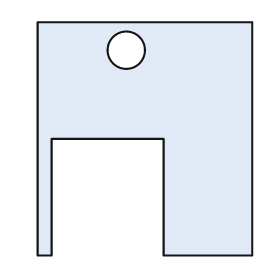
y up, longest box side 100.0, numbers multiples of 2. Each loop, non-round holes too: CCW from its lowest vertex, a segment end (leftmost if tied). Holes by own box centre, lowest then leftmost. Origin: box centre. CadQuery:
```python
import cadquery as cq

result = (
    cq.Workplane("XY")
    .moveTo(-46.0, -50.0)
    .lineTo(-40.0, -50.0)
    .lineTo(-40.0, 0.0)
    .lineTo(8.0, 0.0)
    .lineTo(8.0, -50.0)
    .lineTo(46.0, -50.0)
    .lineTo(46.0, 50.0)
    .lineTo(-46.0, 50.0)
    .close()
    .moveTo(-8.0, 38.0)
    .circle(8.0)
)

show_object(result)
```